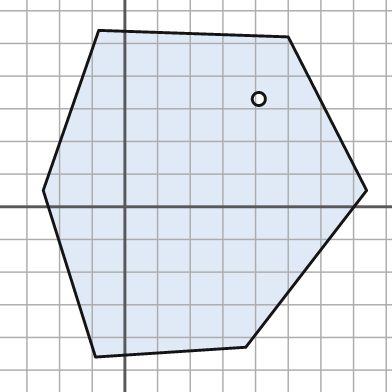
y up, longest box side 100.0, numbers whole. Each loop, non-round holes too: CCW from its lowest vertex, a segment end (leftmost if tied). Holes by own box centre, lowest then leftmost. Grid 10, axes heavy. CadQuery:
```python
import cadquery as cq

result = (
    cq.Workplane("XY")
    .moveTo(-9.0, -46.0)
    .lineTo(37.0, -43.0)
    .lineTo(74.0, 5.0)
    .lineTo(50.0, 52.0)
    .lineTo(-8.0, 54.0)
    .lineTo(-25.0, 5.0)
    .close()
    .moveTo(41.0, 33.0)
    .circle(2.0)
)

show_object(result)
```